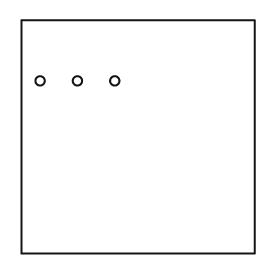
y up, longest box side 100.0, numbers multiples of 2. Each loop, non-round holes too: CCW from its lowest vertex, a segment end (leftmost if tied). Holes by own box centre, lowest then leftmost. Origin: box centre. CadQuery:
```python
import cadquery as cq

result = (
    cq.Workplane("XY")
    .moveTo(-50.0, -50.0)
    .lineTo(50.0, -50.0)
    .lineTo(50.0, 50.0)
    .lineTo(-50.0, 50.0)
    .close()
    .moveTo(-42.0, 24.0)
    .circle(2.0)
    .moveTo(-26.0, 24.0)
    .circle(2.0)
    .moveTo(-10.0, 24.0)
    .circle(2.0)
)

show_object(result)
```